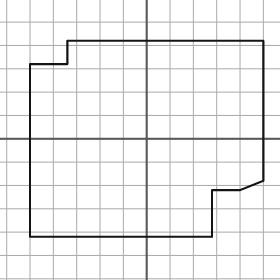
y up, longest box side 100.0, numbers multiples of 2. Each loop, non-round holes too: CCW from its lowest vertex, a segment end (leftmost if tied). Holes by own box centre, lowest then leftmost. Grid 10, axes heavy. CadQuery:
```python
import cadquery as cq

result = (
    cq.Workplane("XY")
    .moveTo(-50.0, -42.0)
    .lineTo(28.0, -42.0)
    .lineTo(28.0, -22.0)
    .lineTo(40.0, -22.0)
    .lineTo(50.0, -18.0)
    .lineTo(50.0, 42.0)
    .lineTo(-34.0, 42.0)
    .lineTo(-34.0, 32.0)
    .lineTo(-50.0, 32.0)
    .close()
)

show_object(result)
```